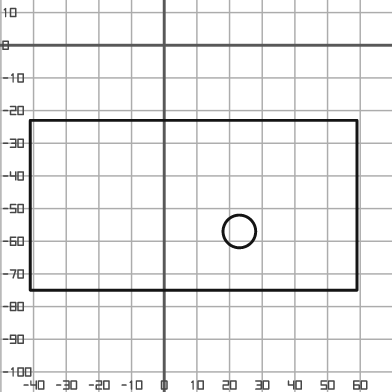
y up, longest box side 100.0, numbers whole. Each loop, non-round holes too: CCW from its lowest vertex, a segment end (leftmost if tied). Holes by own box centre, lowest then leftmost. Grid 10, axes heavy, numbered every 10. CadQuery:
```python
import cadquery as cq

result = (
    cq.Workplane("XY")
    .moveTo(-41.0, -75.0)
    .lineTo(59.0, -75.0)
    .lineTo(59.0, -23.0)
    .lineTo(-41.0, -23.0)
    .close()
    .moveTo(23.0, -57.0)
    .circle(5.0)
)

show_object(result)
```